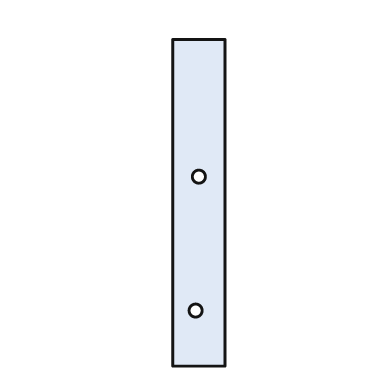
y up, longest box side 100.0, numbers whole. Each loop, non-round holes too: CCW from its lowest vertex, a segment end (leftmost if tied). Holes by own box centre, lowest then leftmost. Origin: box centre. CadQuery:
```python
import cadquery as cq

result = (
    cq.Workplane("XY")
    .moveTo(-8.0, -50.0)
    .lineTo(8.0, -50.0)
    .lineTo(8.0, 50.0)
    .lineTo(-8.0, 50.0)
    .close()
    .moveTo(-1.0, -33.0)
    .circle(2.0)
    .moveTo(0.0, 8.0)
    .circle(2.0)
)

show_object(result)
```